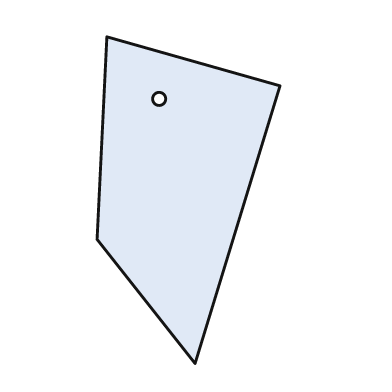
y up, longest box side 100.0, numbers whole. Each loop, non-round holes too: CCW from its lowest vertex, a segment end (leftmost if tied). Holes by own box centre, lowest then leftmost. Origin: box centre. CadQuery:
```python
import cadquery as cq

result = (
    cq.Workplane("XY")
    .moveTo(2.0, -50.0)
    .lineTo(28.0, 35.0)
    .lineTo(-25.0, 50.0)
    .lineTo(-28.0, -12.0)
    .close()
    .moveTo(-9.0, 31.0)
    .circle(2.0)
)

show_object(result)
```